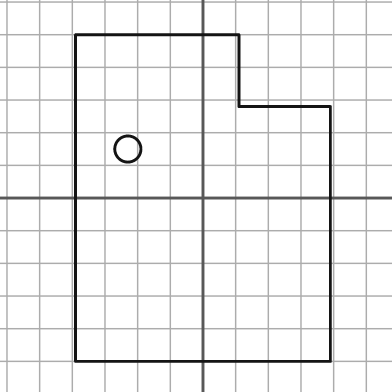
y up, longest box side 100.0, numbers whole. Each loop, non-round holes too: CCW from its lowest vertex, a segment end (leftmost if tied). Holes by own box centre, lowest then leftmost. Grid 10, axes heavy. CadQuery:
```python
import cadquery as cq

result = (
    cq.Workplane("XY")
    .moveTo(-39.0, -50.0)
    .lineTo(39.0, -50.0)
    .lineTo(39.0, 28.0)
    .lineTo(11.0, 28.0)
    .lineTo(11.0, 50.0)
    .lineTo(-39.0, 50.0)
    .close()
    .moveTo(-23.0, 15.0)
    .circle(4.0)
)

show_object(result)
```